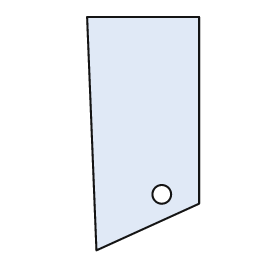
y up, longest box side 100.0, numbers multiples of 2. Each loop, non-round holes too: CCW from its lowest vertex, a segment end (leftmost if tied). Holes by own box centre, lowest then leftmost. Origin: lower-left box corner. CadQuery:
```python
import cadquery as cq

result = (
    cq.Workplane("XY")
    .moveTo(4.0, 0.0)
    .lineTo(48.0, 20.0)
    .lineTo(48.0, 100.0)
    .lineTo(0.0, 100.0)
    .close()
    .moveTo(32.0, 24.0)
    .circle(4.0)
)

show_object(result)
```